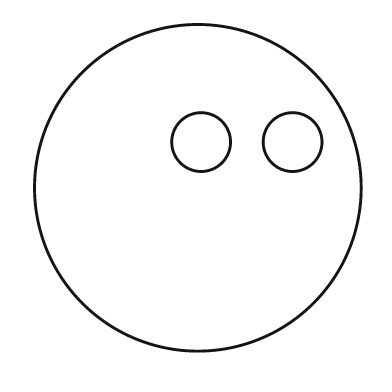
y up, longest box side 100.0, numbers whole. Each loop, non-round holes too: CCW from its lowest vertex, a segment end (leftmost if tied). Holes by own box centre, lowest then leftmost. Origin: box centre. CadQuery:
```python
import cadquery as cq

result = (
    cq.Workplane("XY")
    .moveTo(0.0, 0.0)
    .circle(50.0)
    .moveTo(1.0, 14.0)
    .circle(9.0)
    .moveTo(29.0, 14.0)
    .circle(9.0)
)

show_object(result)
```